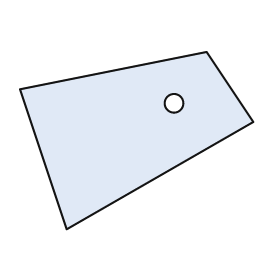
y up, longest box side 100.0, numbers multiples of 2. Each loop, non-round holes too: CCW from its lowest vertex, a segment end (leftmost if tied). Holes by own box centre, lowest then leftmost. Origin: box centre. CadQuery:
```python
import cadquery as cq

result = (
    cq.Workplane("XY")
    .moveTo(-30.0, -38.0)
    .lineTo(50.0, 8.0)
    .lineTo(30.0, 38.0)
    .lineTo(-50.0, 22.0)
    .close()
    .moveTo(16.0, 16.0)
    .circle(4.0)
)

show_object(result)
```